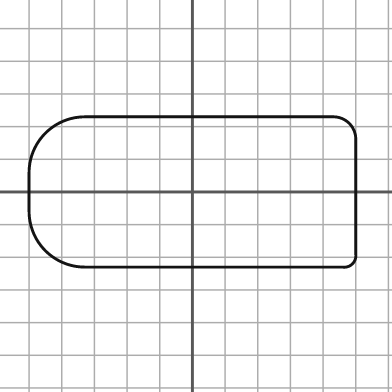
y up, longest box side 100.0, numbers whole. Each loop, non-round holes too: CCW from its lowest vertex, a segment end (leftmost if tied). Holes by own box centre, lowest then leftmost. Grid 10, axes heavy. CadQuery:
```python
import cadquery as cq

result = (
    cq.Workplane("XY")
    .moveTo(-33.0, -23.0)
    .lineTo(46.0, -23.0)
    .threePointArc((49.0, -22.0), (50.0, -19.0))
    .lineTo(50.0, 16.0)
    .threePointArc((48.0, 21.0), (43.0, 23.0))
    .lineTo(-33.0, 23.0)
    .threePointArc((-45.0, 18.0), (-50.0, 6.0))
    .lineTo(-50.0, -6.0)
    .threePointArc((-45.0, -18.0), (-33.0, -23.0))
    .close()
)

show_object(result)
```